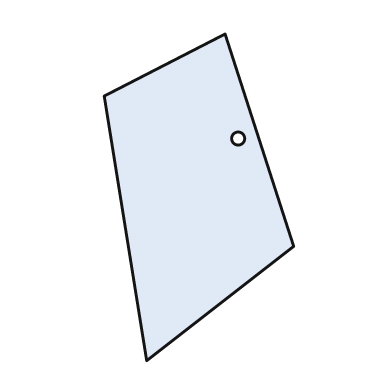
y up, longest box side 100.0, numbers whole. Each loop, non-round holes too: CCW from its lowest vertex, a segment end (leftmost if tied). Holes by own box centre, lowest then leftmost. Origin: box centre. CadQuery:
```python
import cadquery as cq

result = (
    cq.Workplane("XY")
    .moveTo(-16.0, -50.0)
    .lineTo(29.0, -15.0)
    .lineTo(8.0, 50.0)
    .lineTo(-29.0, 31.0)
    .close()
    .moveTo(12.0, 18.0)
    .circle(2.0)
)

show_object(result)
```